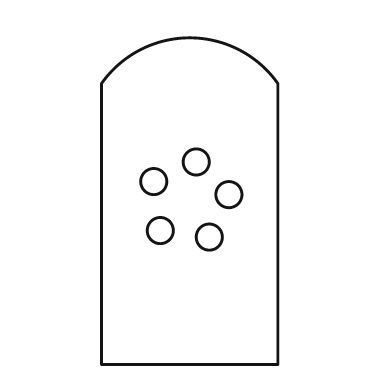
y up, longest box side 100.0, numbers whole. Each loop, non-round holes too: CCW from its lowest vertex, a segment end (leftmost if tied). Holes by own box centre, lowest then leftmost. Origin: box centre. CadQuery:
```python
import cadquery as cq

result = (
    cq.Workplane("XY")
    .moveTo(-27.0, -50.0)
    .lineTo(27.0, -50.0)
    .lineTo(27.0, 36.0)
    .threePointArc((0.0, 50.0), (-27.0, 36.0))
    .close()
    .moveTo(6.0, -11.0)
    .circle(4.0)
    .moveTo(-9.0, -9.0)
    .circle(4.0)
    .moveTo(12.0, 2.0)
    .circle(4.0)
    .moveTo(-11.0, 6.0)
    .circle(4.0)
    .moveTo(2.0, 12.0)
    .circle(4.0)
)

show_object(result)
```